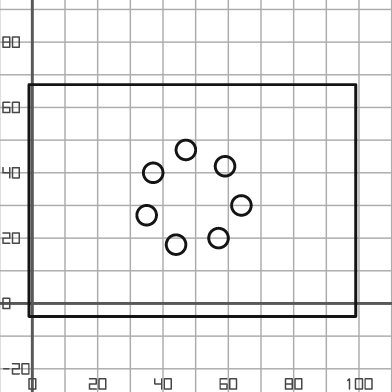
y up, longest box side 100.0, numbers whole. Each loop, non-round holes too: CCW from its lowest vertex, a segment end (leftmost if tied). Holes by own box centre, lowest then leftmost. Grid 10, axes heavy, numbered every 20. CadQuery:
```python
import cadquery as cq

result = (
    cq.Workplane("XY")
    .moveTo(-1.0, -4.0)
    .lineTo(99.0, -4.0)
    .lineTo(99.0, 67.0)
    .lineTo(-1.0, 67.0)
    .close()
    .moveTo(44.0, 18.0)
    .circle(3.0)
    .moveTo(57.0, 20.0)
    .circle(3.0)
    .moveTo(35.0, 27.0)
    .circle(3.0)
    .moveTo(64.0, 30.0)
    .circle(3.0)
    .moveTo(37.0, 40.0)
    .circle(3.0)
    .moveTo(59.0, 42.0)
    .circle(3.0)
    .moveTo(47.0, 47.0)
    .circle(3.0)
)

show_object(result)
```